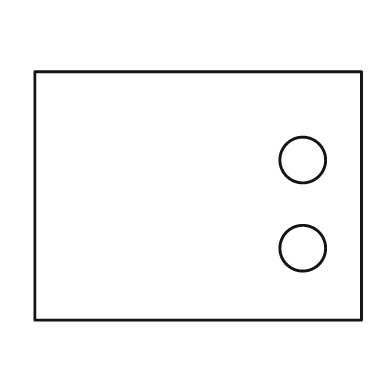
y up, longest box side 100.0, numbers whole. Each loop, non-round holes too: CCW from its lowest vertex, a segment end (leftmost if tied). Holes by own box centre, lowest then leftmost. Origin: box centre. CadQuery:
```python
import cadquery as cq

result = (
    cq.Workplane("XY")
    .moveTo(-50.0, -38.0)
    .lineTo(50.0, -38.0)
    .lineTo(50.0, 38.0)
    .lineTo(-50.0, 38.0)
    .close()
    .moveTo(32.0, -16.0)
    .circle(7.0)
    .moveTo(32.0, 11.0)
    .circle(7.0)
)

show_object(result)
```